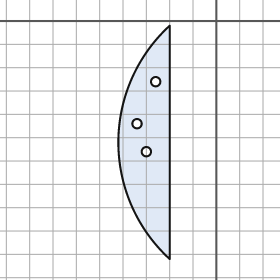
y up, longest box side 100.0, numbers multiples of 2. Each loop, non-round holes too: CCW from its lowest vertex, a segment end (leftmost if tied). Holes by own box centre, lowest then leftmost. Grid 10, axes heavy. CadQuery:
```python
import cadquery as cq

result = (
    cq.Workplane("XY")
    .moveTo(-20.0, -102.0)
    .lineTo(-20.0, -2.0)
    .threePointArc((-42.0, -52.0), (-20.0, -102.0))
    .close()
    .moveTo(-30.0, -56.0)
    .circle(2.0)
    .moveTo(-34.0, -44.0)
    .circle(2.0)
    .moveTo(-26.0, -26.0)
    .circle(2.0)
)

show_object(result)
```